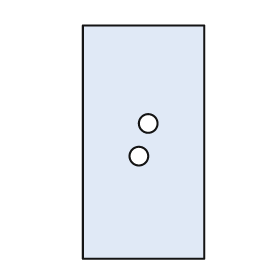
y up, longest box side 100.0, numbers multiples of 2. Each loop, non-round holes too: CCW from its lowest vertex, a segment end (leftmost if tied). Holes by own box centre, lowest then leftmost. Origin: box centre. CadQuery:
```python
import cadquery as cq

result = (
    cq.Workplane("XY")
    .moveTo(-26.0, -50.0)
    .lineTo(26.0, -50.0)
    .lineTo(26.0, 50.0)
    .lineTo(-26.0, 50.0)
    .close()
    .moveTo(-2.0, -6.0)
    .circle(4.0)
    .moveTo(2.0, 8.0)
    .circle(4.0)
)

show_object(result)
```